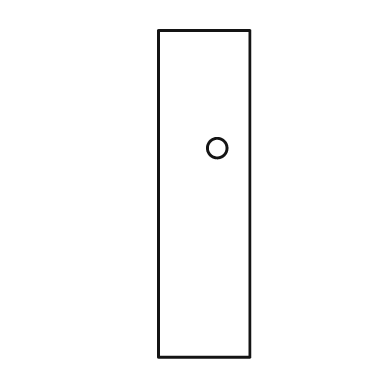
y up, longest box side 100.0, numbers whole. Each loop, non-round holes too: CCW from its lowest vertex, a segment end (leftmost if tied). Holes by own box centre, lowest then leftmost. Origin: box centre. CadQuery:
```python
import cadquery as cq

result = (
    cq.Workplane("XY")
    .moveTo(-14.0, -50.0)
    .lineTo(14.0, -50.0)
    .lineTo(14.0, 50.0)
    .lineTo(-14.0, 50.0)
    .close()
    .moveTo(4.0, 14.0)
    .circle(3.0)
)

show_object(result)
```